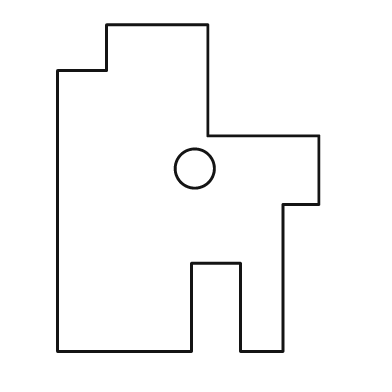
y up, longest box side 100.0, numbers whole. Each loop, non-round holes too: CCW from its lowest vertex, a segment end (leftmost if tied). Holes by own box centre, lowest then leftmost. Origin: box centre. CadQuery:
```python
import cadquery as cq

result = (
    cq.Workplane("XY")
    .moveTo(-40.0, -50.0)
    .lineTo(1.0, -50.0)
    .lineTo(1.0, -23.0)
    .lineTo(16.0, -23.0)
    .lineTo(16.0, -50.0)
    .lineTo(29.0, -50.0)
    .lineTo(29.0, -5.0)
    .lineTo(40.0, -5.0)
    .lineTo(40.0, 16.0)
    .lineTo(6.0, 16.0)
    .lineTo(6.0, 50.0)
    .lineTo(-25.0, 50.0)
    .lineTo(-25.0, 36.0)
    .lineTo(-40.0, 36.0)
    .close()
    .moveTo(2.0, 6.0)
    .circle(6.0)
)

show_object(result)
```